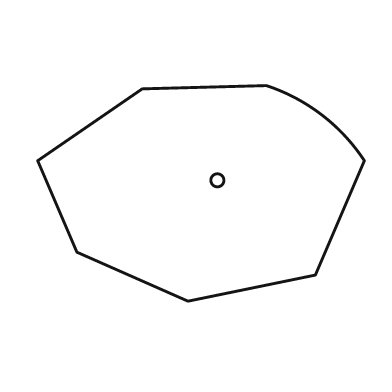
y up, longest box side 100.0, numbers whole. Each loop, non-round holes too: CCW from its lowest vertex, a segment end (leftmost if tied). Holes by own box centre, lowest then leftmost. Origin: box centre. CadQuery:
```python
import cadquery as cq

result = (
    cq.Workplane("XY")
    .moveTo(-4.0, -33.0)
    .lineTo(35.0, -25.0)
    .lineTo(50.0, 10.0)
    .threePointArc((37.0, 24.0), (20.0, 33.0))
    .lineTo(-18.0, 32.0)
    .lineTo(-50.0, 10.0)
    .lineTo(-38.0, -18.0)
    .close()
    .moveTo(5.0, 4.0)
    .circle(2.0)
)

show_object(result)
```